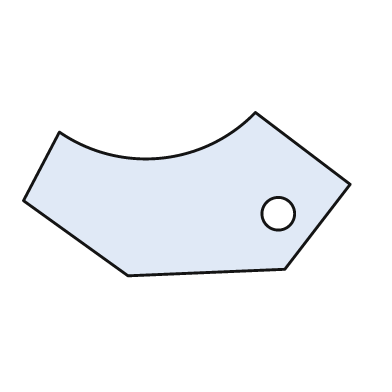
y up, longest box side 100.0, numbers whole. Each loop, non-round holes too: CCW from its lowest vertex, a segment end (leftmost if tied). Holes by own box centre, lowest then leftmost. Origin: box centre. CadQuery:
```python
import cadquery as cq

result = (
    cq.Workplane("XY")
    .moveTo(-18.0, -25.0)
    .lineTo(30.0, -23.0)
    .lineTo(50.0, 3.0)
    .lineTo(21.0, 25.0)
    .threePointArc((-8.0, 11.0), (-39.0, 19.0))
    .lineTo(-50.0, -2.0)
    .close()
    .moveTo(28.0, -6.0)
    .circle(5.0)
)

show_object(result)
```